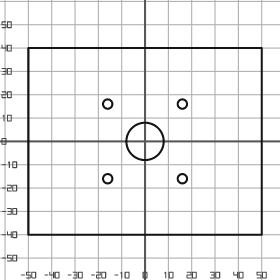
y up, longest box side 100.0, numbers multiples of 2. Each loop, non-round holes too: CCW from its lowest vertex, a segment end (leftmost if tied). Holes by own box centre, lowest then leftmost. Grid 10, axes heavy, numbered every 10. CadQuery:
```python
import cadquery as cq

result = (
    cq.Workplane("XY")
    .moveTo(-50.0, -40.0)
    .lineTo(50.0, -40.0)
    .lineTo(50.0, 40.0)
    .lineTo(-50.0, 40.0)
    .close()
    .moveTo(-16.0, -16.0)
    .circle(2.0)
    .moveTo(16.0, -16.0)
    .circle(2.0)
    .moveTo(0.0, 0.0)
    .circle(8.0)
    .moveTo(-16.0, 16.0)
    .circle(2.0)
    .moveTo(16.0, 16.0)
    .circle(2.0)
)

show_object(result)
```